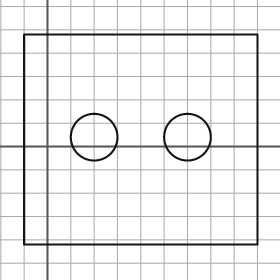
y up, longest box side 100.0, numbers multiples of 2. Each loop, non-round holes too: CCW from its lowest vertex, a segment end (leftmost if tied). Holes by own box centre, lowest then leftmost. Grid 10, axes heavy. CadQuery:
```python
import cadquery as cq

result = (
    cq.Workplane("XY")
    .moveTo(-10.0, -42.0)
    .lineTo(90.0, -42.0)
    .lineTo(90.0, 48.0)
    .lineTo(-10.0, 48.0)
    .close()
    .moveTo(20.0, 4.0)
    .circle(10.0)
    .moveTo(60.0, 4.0)
    .circle(10.0)
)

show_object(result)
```